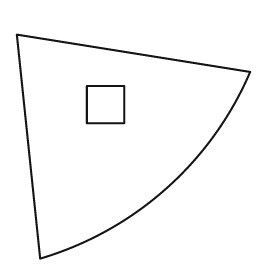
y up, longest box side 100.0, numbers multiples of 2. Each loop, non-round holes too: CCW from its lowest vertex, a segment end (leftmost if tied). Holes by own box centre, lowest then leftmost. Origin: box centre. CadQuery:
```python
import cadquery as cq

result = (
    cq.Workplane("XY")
    .moveTo(-40.0, -48.0)
    .threePointArc((14.0, -18.0), (50.0, 32.0))
    .lineTo(-50.0, 48.0)
    .close()
    .moveTo(-20.0, 10.0)
    .lineTo(-4.0, 10.0)
    .lineTo(-4.0, 26.0)
    .lineTo(-20.0, 26.0)
    .close()
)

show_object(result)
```